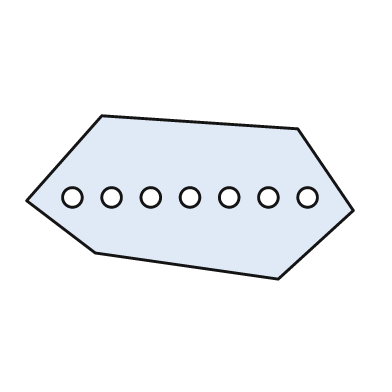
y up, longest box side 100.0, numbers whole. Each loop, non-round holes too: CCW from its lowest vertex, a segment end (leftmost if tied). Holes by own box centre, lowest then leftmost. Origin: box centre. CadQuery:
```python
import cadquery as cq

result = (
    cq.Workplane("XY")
    .moveTo(27.0, -25.0)
    .lineTo(50.0, -4.0)
    .lineTo(33.0, 21.0)
    .lineTo(-27.0, 25.0)
    .lineTo(-50.0, -1.0)
    .lineTo(-29.0, -17.0)
    .close()
    .moveTo(-36.0, 0.0)
    .circle(3.0)
    .moveTo(-24.0, 0.0)
    .circle(3.0)
    .moveTo(-12.0, 0.0)
    .circle(3.0)
    .moveTo(0.0, 0.0)
    .circle(3.0)
    .moveTo(12.0, 0.0)
    .circle(3.0)
    .moveTo(24.0, 0.0)
    .circle(3.0)
    .moveTo(36.0, 0.0)
    .circle(3.0)
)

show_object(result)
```